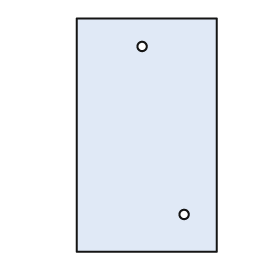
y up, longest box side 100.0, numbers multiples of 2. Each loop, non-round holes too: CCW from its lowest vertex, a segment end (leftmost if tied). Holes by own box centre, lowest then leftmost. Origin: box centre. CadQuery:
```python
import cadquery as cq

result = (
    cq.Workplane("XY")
    .moveTo(-30.0, -50.0)
    .lineTo(30.0, -50.0)
    .lineTo(30.0, 50.0)
    .lineTo(-30.0, 50.0)
    .close()
    .moveTo(16.0, -34.0)
    .circle(2.0)
    .moveTo(-2.0, 38.0)
    .circle(2.0)
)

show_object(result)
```